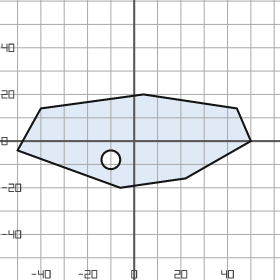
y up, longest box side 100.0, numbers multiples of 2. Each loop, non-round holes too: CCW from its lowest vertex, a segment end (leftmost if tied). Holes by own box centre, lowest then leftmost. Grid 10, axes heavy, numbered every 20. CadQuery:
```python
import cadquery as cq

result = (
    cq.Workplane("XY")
    .moveTo(-6.0, -20.0)
    .lineTo(22.0, -16.0)
    .lineTo(50.0, 0.0)
    .lineTo(44.0, 14.0)
    .lineTo(4.0, 20.0)
    .lineTo(-40.0, 14.0)
    .lineTo(-50.0, -4.0)
    .close()
    .moveTo(-10.0, -8.0)
    .circle(4.0)
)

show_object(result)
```